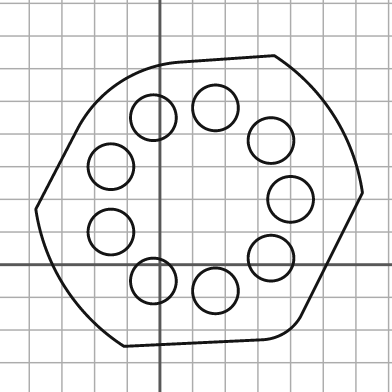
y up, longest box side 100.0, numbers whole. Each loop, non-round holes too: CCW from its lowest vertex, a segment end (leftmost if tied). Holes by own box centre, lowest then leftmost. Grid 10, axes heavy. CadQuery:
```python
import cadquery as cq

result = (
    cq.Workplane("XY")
    .moveTo(-11.0, -25.0)
    .lineTo(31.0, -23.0)
    .threePointArc((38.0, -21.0), (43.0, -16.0))
    .lineTo(62.0, 22.0)
    .threePointArc((53.0, 46.0), (35.0, 64.0))
    .lineTo(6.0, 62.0)
    .threePointArc((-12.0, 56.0), (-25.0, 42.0))
    .lineTo(-38.0, 17.0)
    .threePointArc((-29.0, -7.0), (-11.0, -25.0))
    .close()
    .moveTo(17.0, -8.0)
    .circle(7.0)
    .moveTo(-2.0, -5.0)
    .circle(7.0)
    .moveTo(34.0, 2.0)
    .circle(7.0)
    .moveTo(-15.0, 10.0)
    .circle(7.0)
    .moveTo(40.0, 20.0)
    .circle(7.0)
    .moveTo(-15.0, 30.0)
    .circle(7.0)
    .moveTo(34.0, 38.0)
    .circle(7.0)
    .moveTo(-2.0, 45.0)
    .circle(7.0)
    .moveTo(17.0, 48.0)
    .circle(7.0)
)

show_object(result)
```